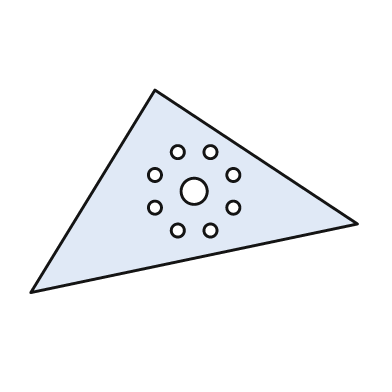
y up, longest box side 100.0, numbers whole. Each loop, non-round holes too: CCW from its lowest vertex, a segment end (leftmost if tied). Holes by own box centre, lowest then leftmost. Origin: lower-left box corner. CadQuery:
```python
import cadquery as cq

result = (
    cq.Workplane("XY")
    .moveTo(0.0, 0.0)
    .lineTo(100.0, 21.0)
    .lineTo(38.0, 62.0)
    .close()
    .moveTo(45.0, 19.0)
    .circle(2.0)
    .moveTo(55.0, 19.0)
    .circle(2.0)
    .moveTo(38.0, 26.0)
    .circle(2.0)
    .moveTo(62.0, 26.0)
    .circle(2.0)
    .moveTo(50.0, 31.0)
    .circle(4.0)
    .moveTo(38.0, 36.0)
    .circle(2.0)
    .moveTo(62.0, 36.0)
    .circle(2.0)
    .moveTo(45.0, 43.0)
    .circle(2.0)
    .moveTo(55.0, 43.0)
    .circle(2.0)
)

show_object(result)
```